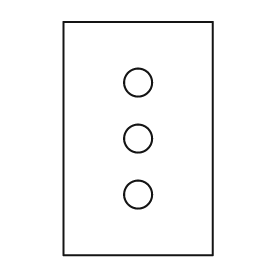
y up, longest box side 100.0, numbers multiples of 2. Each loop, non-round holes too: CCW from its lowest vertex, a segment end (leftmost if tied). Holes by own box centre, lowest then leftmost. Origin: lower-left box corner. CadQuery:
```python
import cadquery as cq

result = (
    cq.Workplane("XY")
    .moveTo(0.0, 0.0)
    .lineTo(64.0, 0.0)
    .lineTo(64.0, 100.0)
    .lineTo(0.0, 100.0)
    .close()
    .moveTo(32.0, 26.0)
    .circle(6.0)
    .moveTo(32.0, 50.0)
    .circle(6.0)
    .moveTo(32.0, 74.0)
    .circle(6.0)
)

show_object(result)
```